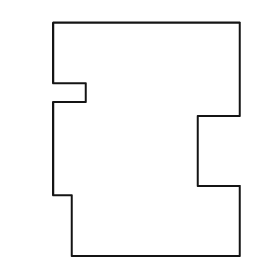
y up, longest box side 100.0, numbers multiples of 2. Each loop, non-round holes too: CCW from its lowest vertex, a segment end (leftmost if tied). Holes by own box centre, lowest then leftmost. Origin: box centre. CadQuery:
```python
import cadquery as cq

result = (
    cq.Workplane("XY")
    .moveTo(-32.0, -50.0)
    .lineTo(40.0, -50.0)
    .lineTo(40.0, -20.0)
    .lineTo(22.0, -20.0)
    .lineTo(22.0, 10.0)
    .lineTo(40.0, 10.0)
    .lineTo(40.0, 50.0)
    .lineTo(-40.0, 50.0)
    .lineTo(-40.0, 24.0)
    .lineTo(-26.0, 24.0)
    .lineTo(-26.0, 16.0)
    .lineTo(-40.0, 16.0)
    .lineTo(-40.0, -24.0)
    .lineTo(-32.0, -24.0)
    .close()
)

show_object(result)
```